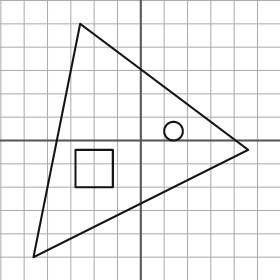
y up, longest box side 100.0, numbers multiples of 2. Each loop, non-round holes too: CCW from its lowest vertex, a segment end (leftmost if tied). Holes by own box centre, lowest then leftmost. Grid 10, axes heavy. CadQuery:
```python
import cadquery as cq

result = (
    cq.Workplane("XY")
    .moveTo(-46.0, -50.0)
    .lineTo(46.0, -4.0)
    .lineTo(-26.0, 50.0)
    .close()
    .moveTo(-28.0, -20.0)
    .lineTo(-12.0, -20.0)
    .lineTo(-12.0, -4.0)
    .lineTo(-28.0, -4.0)
    .close()
    .moveTo(14.0, 4.0)
    .circle(4.0)
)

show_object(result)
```